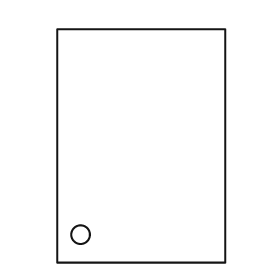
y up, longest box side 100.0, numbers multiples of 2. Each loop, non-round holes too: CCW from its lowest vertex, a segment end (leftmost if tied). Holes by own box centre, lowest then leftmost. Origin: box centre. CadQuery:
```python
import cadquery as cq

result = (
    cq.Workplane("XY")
    .moveTo(-36.0, -50.0)
    .lineTo(36.0, -50.0)
    .lineTo(36.0, 50.0)
    .lineTo(-36.0, 50.0)
    .close()
    .moveTo(-26.0, -38.0)
    .circle(4.0)
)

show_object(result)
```